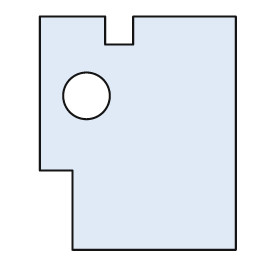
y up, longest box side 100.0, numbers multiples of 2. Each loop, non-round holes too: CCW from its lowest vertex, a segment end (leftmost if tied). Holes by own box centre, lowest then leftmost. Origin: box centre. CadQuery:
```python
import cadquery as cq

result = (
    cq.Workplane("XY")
    .moveTo(-28.0, -50.0)
    .lineTo(42.0, -50.0)
    .lineTo(42.0, 50.0)
    .lineTo(-2.0, 50.0)
    .lineTo(-2.0, 38.0)
    .lineTo(-14.0, 38.0)
    .lineTo(-14.0, 50.0)
    .lineTo(-42.0, 50.0)
    .lineTo(-42.0, -16.0)
    .lineTo(-28.0, -16.0)
    .close()
    .moveTo(-22.0, 16.0)
    .circle(10.0)
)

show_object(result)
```